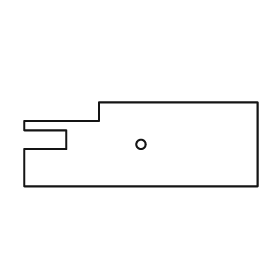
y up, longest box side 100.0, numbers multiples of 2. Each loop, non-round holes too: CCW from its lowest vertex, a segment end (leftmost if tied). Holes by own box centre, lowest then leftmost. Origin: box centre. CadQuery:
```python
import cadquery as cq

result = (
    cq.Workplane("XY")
    .moveTo(-50.0, -18.0)
    .lineTo(50.0, -18.0)
    .lineTo(50.0, 18.0)
    .lineTo(-18.0, 18.0)
    .lineTo(-18.0, 10.0)
    .lineTo(-50.0, 10.0)
    .lineTo(-50.0, 6.0)
    .lineTo(-32.0, 6.0)
    .lineTo(-32.0, -2.0)
    .lineTo(-50.0, -2.0)
    .close()
    .moveTo(0.0, 0.0)
    .circle(2.0)
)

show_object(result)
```